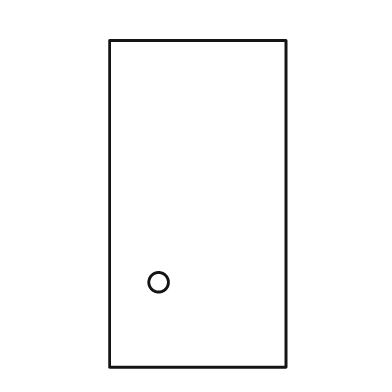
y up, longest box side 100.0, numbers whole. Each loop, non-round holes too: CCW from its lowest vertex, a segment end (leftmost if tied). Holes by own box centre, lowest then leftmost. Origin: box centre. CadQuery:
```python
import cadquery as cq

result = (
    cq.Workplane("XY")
    .moveTo(-27.0, -50.0)
    .lineTo(27.0, -50.0)
    .lineTo(27.0, 50.0)
    .lineTo(-27.0, 50.0)
    .close()
    .moveTo(-12.0, -24.0)
    .circle(3.0)
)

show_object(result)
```